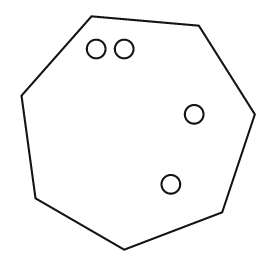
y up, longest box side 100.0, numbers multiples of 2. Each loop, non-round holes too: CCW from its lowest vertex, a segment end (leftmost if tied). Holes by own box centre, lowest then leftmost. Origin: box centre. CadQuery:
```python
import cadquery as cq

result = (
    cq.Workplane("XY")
    .moveTo(-6.0, -50.0)
    .lineTo(36.0, -34.0)
    .lineTo(50.0, 8.0)
    .lineTo(26.0, 46.0)
    .lineTo(-20.0, 50.0)
    .lineTo(-50.0, 16.0)
    .lineTo(-44.0, -28.0)
    .close()
    .moveTo(14.0, -22.0)
    .circle(4.0)
    .moveTo(24.0, 8.0)
    .circle(4.0)
    .moveTo(-18.0, 36.0)
    .circle(4.0)
    .moveTo(-6.0, 36.0)
    .circle(4.0)
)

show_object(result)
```